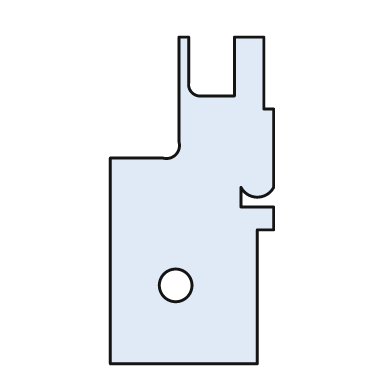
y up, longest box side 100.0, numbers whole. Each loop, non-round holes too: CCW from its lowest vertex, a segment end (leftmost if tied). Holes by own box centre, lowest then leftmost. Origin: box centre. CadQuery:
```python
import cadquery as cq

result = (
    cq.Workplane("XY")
    .moveTo(-25.0, -50.0)
    .lineTo(20.0, -50.0)
    .lineTo(20.0, -9.0)
    .lineTo(25.0, -9.0)
    .lineTo(25.0, -2.0)
    .lineTo(15.0, -2.0)
    .lineTo(15.0, 4.0)
    .threePointArc((20.0, 1.0), (25.0, 4.0))
    .lineTo(25.0, 28.0)
    .lineTo(22.0, 28.0)
    .lineTo(22.0, 50.0)
    .lineTo(13.0, 50.0)
    .lineTo(13.0, 32.0)
    .lineTo(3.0, 32.0)
    .threePointArc((0.0, 33.0), (-1.0, 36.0))
    .lineTo(-1.0, 50.0)
    .lineTo(-4.0, 50.0)
    .lineTo(-4.0, 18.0)
    .threePointArc((-5.0, 14.0), (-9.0, 13.0))
    .lineTo(-25.0, 13.0)
    .close()
    .moveTo(-5.0, -26.0)
    .circle(5.0)
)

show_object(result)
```